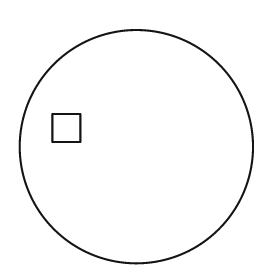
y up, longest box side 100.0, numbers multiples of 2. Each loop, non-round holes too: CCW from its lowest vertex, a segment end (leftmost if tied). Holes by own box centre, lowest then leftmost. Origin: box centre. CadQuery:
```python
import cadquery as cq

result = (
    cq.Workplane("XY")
    .moveTo(0.0, 0.0)
    .circle(50.0)
    .moveTo(-36.0, 2.0)
    .lineTo(-24.0, 2.0)
    .lineTo(-24.0, 14.0)
    .lineTo(-36.0, 14.0)
    .close()
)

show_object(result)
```